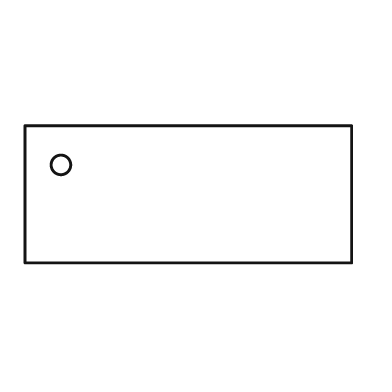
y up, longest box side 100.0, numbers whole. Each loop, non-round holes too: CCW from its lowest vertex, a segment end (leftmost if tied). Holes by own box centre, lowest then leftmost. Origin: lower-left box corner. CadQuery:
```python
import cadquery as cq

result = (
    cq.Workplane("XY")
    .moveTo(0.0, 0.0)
    .lineTo(100.0, 0.0)
    .lineTo(100.0, 42.0)
    .lineTo(0.0, 42.0)
    .close()
    .moveTo(11.0, 30.0)
    .circle(3.0)
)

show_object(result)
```